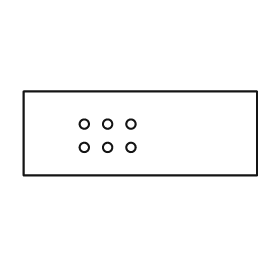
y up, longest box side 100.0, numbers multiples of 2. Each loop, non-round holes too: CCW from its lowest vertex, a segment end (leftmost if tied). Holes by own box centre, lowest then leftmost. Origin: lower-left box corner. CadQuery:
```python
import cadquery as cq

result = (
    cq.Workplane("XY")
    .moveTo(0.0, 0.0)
    .lineTo(100.0, 0.0)
    .lineTo(100.0, 36.0)
    .lineTo(0.0, 36.0)
    .close()
    .moveTo(26.0, 12.0)
    .circle(2.0)
    .moveTo(36.0, 12.0)
    .circle(2.0)
    .moveTo(46.0, 12.0)
    .circle(2.0)
    .moveTo(26.0, 22.0)
    .circle(2.0)
    .moveTo(36.0, 22.0)
    .circle(2.0)
    .moveTo(46.0, 22.0)
    .circle(2.0)
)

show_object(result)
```